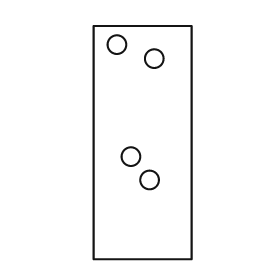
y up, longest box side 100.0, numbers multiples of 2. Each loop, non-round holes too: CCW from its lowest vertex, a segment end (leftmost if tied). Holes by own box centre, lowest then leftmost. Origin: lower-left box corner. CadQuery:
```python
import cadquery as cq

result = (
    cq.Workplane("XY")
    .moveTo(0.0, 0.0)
    .lineTo(42.0, 0.0)
    .lineTo(42.0, 100.0)
    .lineTo(0.0, 100.0)
    .close()
    .moveTo(24.0, 34.0)
    .circle(4.0)
    .moveTo(16.0, 44.0)
    .circle(4.0)
    .moveTo(26.0, 86.0)
    .circle(4.0)
    .moveTo(10.0, 92.0)
    .circle(4.0)
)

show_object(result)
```